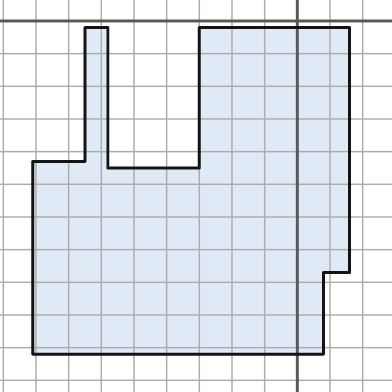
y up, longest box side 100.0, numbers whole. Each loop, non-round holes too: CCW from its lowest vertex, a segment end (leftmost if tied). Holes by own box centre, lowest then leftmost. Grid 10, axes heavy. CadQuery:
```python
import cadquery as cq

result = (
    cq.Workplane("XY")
    .moveTo(-81.0, -102.0)
    .lineTo(8.0, -102.0)
    .lineTo(8.0, -77.0)
    .lineTo(16.0, -77.0)
    .lineTo(16.0, -2.0)
    .lineTo(-30.0, -2.0)
    .lineTo(-30.0, -45.0)
    .lineTo(-58.0, -45.0)
    .lineTo(-58.0, -2.0)
    .lineTo(-65.0, -2.0)
    .lineTo(-65.0, -43.0)
    .lineTo(-81.0, -43.0)
    .close()
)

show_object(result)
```